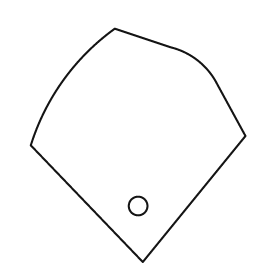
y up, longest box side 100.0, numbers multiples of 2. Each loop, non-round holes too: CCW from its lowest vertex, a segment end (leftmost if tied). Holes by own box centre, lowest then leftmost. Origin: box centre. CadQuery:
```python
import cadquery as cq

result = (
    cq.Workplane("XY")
    .moveTo(2.0, -50.0)
    .lineTo(46.0, 4.0)
    .lineTo(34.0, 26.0)
    .threePointArc((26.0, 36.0), (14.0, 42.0))
    .lineTo(-10.0, 50.0)
    .threePointArc((-32.0, 28.0), (-46.0, 0.0))
    .close()
    .moveTo(0.0, -26.0)
    .circle(4.0)
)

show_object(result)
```